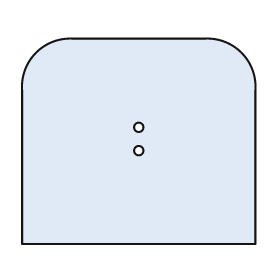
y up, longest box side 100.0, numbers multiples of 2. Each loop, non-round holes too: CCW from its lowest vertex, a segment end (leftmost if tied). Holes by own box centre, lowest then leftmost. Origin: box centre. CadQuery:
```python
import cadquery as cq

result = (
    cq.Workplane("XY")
    .moveTo(-50.0, -44.0)
    .lineTo(50.0, -44.0)
    .lineTo(50.0, 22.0)
    .threePointArc((44.0, 38.0), (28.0, 44.0))
    .lineTo(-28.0, 44.0)
    .threePointArc((-44.0, 38.0), (-50.0, 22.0))
    .close()
    .moveTo(0.0, -4.0)
    .circle(2.0)
    .moveTo(0.0, 6.0)
    .circle(2.0)
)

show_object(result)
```